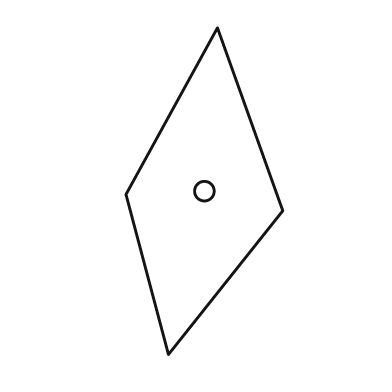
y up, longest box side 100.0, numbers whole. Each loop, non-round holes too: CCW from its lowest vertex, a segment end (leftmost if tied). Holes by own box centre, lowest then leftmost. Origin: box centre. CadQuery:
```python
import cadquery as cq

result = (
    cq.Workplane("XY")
    .moveTo(-11.0, -50.0)
    .lineTo(24.0, -6.0)
    .lineTo(4.0, 50.0)
    .lineTo(-24.0, -1.0)
    .close()
    .moveTo(0.0, 0.0)
    .circle(3.0)
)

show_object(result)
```